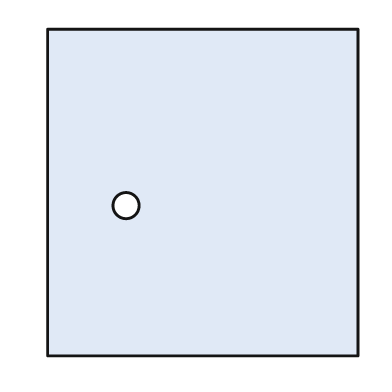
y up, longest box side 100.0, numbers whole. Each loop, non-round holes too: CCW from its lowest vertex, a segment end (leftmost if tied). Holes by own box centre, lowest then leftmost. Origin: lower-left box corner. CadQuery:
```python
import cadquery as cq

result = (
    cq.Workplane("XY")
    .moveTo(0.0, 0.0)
    .lineTo(95.0, 0.0)
    .lineTo(95.0, 100.0)
    .lineTo(0.0, 100.0)
    .close()
    .moveTo(24.0, 46.0)
    .circle(4.0)
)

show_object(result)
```